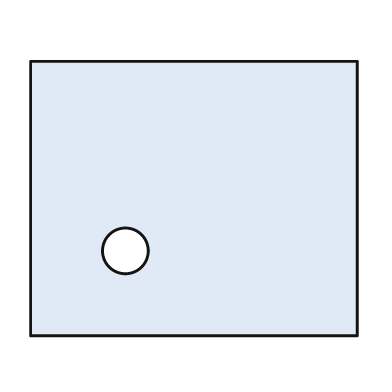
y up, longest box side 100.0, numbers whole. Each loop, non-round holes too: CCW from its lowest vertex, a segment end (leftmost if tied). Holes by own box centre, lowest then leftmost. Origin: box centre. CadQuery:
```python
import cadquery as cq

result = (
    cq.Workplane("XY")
    .moveTo(-50.0, -42.0)
    .lineTo(50.0, -42.0)
    .lineTo(50.0, 42.0)
    .lineTo(-50.0, 42.0)
    .close()
    .moveTo(-21.0, -16.0)
    .circle(7.0)
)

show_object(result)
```